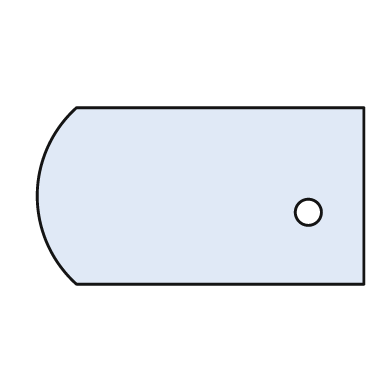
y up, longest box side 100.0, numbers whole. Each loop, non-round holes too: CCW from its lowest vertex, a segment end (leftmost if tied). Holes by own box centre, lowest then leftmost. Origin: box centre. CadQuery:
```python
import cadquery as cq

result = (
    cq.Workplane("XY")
    .moveTo(-38.0, -27.0)
    .lineTo(50.0, -27.0)
    .lineTo(50.0, 27.0)
    .lineTo(-38.0, 27.0)
    .threePointArc((-50.0, 0.0), (-38.0, -27.0))
    .close()
    .moveTo(33.0, -5.0)
    .circle(4.0)
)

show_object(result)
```